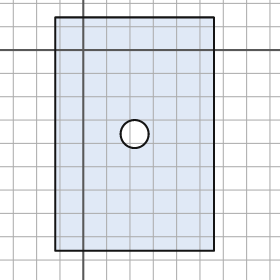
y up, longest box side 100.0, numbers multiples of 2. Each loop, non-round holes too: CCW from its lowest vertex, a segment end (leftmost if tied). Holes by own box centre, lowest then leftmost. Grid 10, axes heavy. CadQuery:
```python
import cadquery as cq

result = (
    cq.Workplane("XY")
    .moveTo(-12.0, -86.0)
    .lineTo(56.0, -86.0)
    .lineTo(56.0, 14.0)
    .lineTo(-12.0, 14.0)
    .close()
    .moveTo(22.0, -36.0)
    .circle(6.0)
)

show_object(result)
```